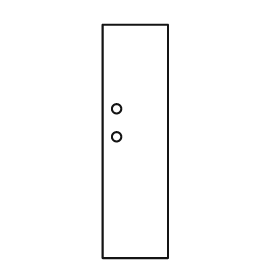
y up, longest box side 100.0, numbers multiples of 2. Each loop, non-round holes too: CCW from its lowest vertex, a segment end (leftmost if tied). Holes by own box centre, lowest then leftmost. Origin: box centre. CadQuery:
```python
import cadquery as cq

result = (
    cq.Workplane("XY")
    .moveTo(-14.0, -50.0)
    .lineTo(14.0, -50.0)
    .lineTo(14.0, 50.0)
    .lineTo(-14.0, 50.0)
    .close()
    .moveTo(-8.0, 2.0)
    .circle(2.0)
    .moveTo(-8.0, 14.0)
    .circle(2.0)
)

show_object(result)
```